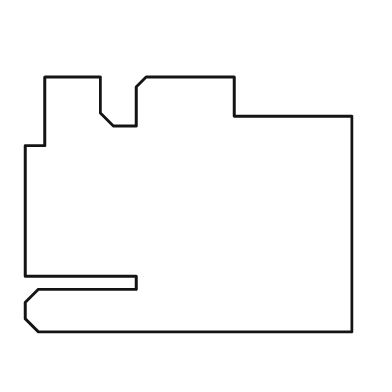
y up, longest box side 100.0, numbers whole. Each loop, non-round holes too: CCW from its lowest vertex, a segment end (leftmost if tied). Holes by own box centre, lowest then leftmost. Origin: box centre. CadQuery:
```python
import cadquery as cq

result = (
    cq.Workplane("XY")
    .moveTo(-46.0, -39.0)
    .lineTo(50.0, -39.0)
    .lineTo(50.0, 27.0)
    .lineTo(14.0, 27.0)
    .lineTo(14.0, 39.0)
    .lineTo(-13.0, 39.0)
    .lineTo(-16.0, 36.0)
    .lineTo(-16.0, 24.0)
    .lineTo(-23.0, 24.0)
    .lineTo(-27.0, 28.0)
    .lineTo(-27.0, 39.0)
    .lineTo(-44.0, 39.0)
    .lineTo(-44.0, 18.0)
    .lineTo(-50.0, 18.0)
    .lineTo(-50.0, -22.0)
    .lineTo(-16.0, -22.0)
    .lineTo(-16.0, -26.0)
    .lineTo(-46.0, -26.0)
    .lineTo(-50.0, -30.0)
    .lineTo(-50.0, -35.0)
    .close()
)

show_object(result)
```